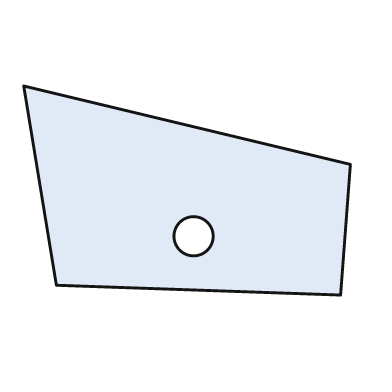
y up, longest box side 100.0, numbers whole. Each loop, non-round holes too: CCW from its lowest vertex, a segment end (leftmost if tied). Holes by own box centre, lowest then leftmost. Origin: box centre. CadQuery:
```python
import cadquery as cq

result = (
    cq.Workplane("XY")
    .moveTo(47.0, -32.0)
    .lineTo(50.0, 8.0)
    .lineTo(-50.0, 32.0)
    .lineTo(-40.0, -29.0)
    .close()
    .moveTo(2.0, -14.0)
    .circle(6.0)
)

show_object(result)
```